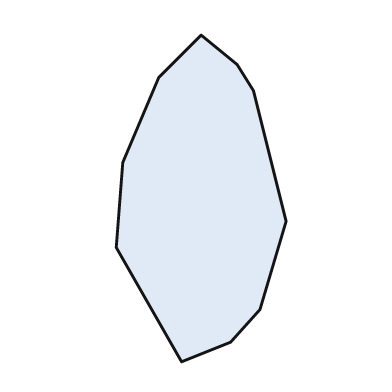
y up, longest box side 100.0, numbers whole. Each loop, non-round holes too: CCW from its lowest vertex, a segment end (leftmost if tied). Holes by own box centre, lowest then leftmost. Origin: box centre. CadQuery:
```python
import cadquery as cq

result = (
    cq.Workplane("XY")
    .moveTo(-6.0, -50.0)
    .lineTo(9.0, -44.0)
    .lineTo(18.0, -34.0)
    .lineTo(26.0, -7.0)
    .lineTo(16.0, 33.0)
    .lineTo(11.0, 41.0)
    .lineTo(0.0, 50.0)
    .lineTo(-13.0, 37.0)
    .lineTo(-24.0, 11.0)
    .lineTo(-26.0, -15.0)
    .close()
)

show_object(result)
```